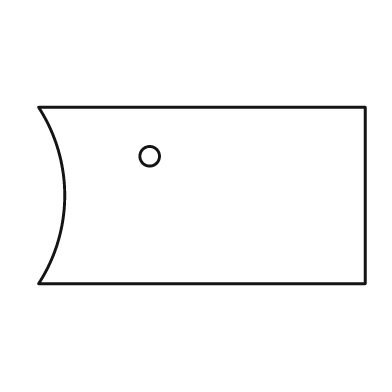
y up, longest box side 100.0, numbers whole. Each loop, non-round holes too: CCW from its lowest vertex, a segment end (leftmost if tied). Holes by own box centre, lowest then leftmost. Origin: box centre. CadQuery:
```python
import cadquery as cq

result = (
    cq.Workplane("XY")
    .moveTo(-50.0, -27.0)
    .lineTo(50.0, -27.0)
    .lineTo(50.0, 27.0)
    .lineTo(-50.0, 27.0)
    .threePointArc((-42.0, 0.0), (-50.0, -27.0))
    .close()
    .moveTo(-16.0, 12.0)
    .circle(3.0)
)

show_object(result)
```